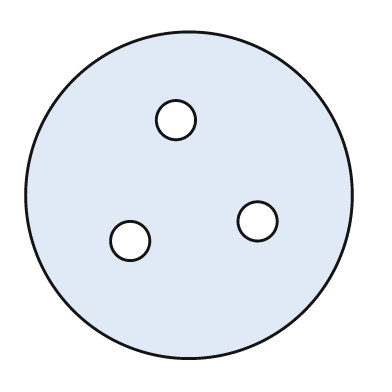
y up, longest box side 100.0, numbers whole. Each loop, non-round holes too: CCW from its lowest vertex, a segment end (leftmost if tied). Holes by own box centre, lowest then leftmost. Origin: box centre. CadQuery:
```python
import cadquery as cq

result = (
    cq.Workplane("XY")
    .moveTo(0.0, 0.0)
    .circle(50.0)
    .moveTo(-18.0, -14.0)
    .circle(6.0)
    .moveTo(21.0, -8.0)
    .circle(6.0)
    .moveTo(-4.0, 23.0)
    .circle(6.0)
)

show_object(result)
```